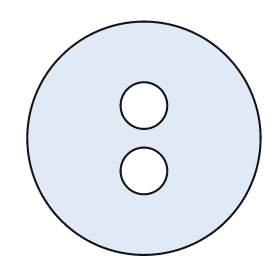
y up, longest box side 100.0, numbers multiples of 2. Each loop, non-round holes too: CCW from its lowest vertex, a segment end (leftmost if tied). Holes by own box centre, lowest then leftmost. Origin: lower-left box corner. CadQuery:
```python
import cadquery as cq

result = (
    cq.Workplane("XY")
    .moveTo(50.0, 50.0)
    .circle(50.0)
    .moveTo(50.0, 36.0)
    .circle(10.0)
    .moveTo(50.0, 64.0)
    .circle(10.0)
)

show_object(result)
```